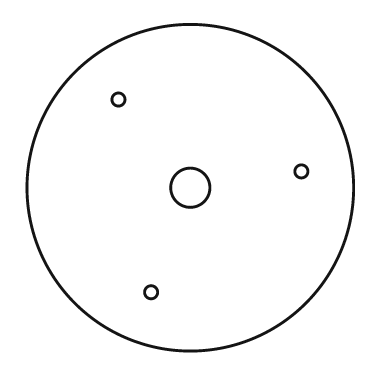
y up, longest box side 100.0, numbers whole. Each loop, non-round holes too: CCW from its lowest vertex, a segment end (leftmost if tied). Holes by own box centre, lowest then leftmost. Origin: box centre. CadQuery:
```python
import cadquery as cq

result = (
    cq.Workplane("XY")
    .moveTo(0.0, 0.0)
    .circle(50.0)
    .moveTo(-12.0, -32.0)
    .circle(2.0)
    .moveTo(0.0, 0.0)
    .circle(6.0)
    .moveTo(34.0, 5.0)
    .circle(2.0)
    .moveTo(-22.0, 27.0)
    .circle(2.0)
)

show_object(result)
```